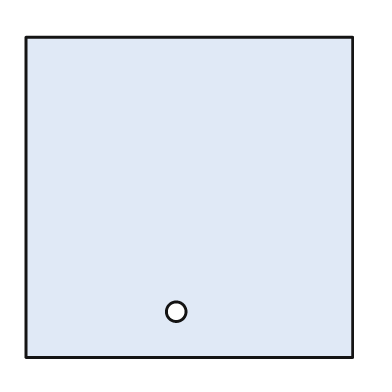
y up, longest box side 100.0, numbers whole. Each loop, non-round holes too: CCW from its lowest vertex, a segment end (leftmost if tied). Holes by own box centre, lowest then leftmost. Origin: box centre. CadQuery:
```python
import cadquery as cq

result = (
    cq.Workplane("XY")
    .moveTo(-50.0, -49.0)
    .lineTo(50.0, -49.0)
    .lineTo(50.0, 49.0)
    .lineTo(-50.0, 49.0)
    .close()
    .moveTo(-4.0, -35.0)
    .circle(3.0)
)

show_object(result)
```